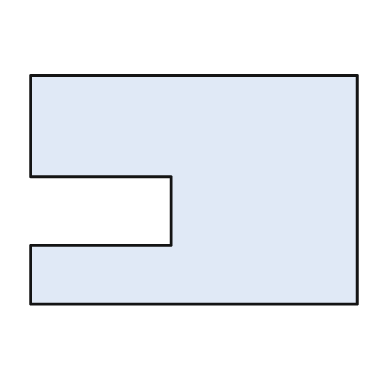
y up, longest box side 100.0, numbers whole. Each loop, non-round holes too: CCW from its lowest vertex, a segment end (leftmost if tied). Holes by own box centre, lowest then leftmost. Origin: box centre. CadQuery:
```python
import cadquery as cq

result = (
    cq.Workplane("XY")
    .moveTo(-50.0, -35.0)
    .lineTo(50.0, -35.0)
    .lineTo(50.0, 35.0)
    .lineTo(-50.0, 35.0)
    .lineTo(-50.0, 4.0)
    .lineTo(-7.0, 4.0)
    .lineTo(-7.0, -17.0)
    .lineTo(-50.0, -17.0)
    .close()
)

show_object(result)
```